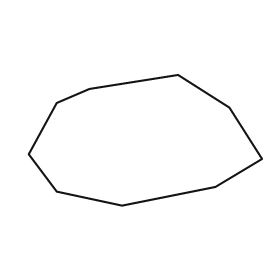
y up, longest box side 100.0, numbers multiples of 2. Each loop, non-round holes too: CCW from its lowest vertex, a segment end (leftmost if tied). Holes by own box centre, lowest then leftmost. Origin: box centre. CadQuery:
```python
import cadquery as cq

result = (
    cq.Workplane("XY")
    .moveTo(-10.0, -28.0)
    .lineTo(30.0, -20.0)
    .lineTo(50.0, -8.0)
    .lineTo(36.0, 14.0)
    .lineTo(14.0, 28.0)
    .lineTo(-24.0, 22.0)
    .lineTo(-38.0, 16.0)
    .lineTo(-50.0, -6.0)
    .lineTo(-38.0, -22.0)
    .close()
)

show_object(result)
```